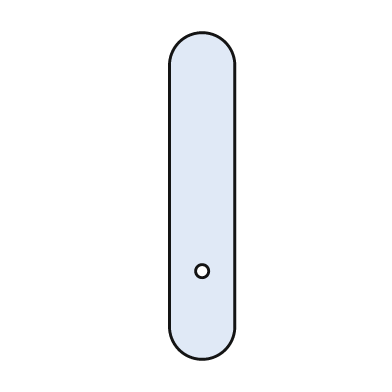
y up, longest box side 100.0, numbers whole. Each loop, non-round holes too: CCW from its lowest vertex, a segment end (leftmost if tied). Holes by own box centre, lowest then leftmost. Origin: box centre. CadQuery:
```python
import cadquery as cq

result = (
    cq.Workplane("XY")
    .moveTo(-10.0, -40.0)
    .threePointArc((0.0, -50.0), (10.0, -40.0))
    .lineTo(10.0, 40.0)
    .threePointArc((0.0, 50.0), (-10.0, 40.0))
    .close()
    .moveTo(0.0, -23.0)
    .circle(2.0)
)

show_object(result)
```